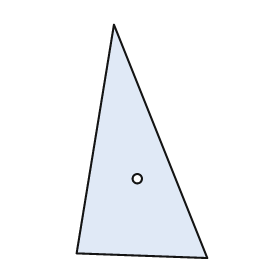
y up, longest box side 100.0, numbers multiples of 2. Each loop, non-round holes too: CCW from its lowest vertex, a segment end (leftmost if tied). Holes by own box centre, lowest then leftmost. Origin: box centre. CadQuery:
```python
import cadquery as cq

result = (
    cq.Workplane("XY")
    .moveTo(28.0, -50.0)
    .lineTo(-12.0, 50.0)
    .lineTo(-28.0, -48.0)
    .close()
    .moveTo(-2.0, -16.0)
    .circle(2.0)
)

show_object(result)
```